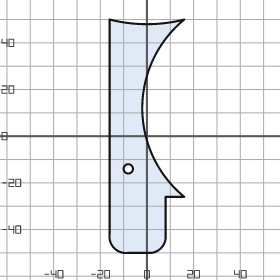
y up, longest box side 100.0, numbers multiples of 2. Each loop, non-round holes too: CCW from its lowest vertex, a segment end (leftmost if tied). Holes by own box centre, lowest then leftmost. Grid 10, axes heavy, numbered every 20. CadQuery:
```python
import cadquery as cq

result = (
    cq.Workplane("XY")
    .moveTo(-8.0, -50.0)
    .lineTo(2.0, -50.0)
    .threePointArc((6.0, -48.0), (8.0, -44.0))
    .lineTo(8.0, -26.0)
    .lineTo(16.0, -26.0)
    .threePointArc((-2.0, 12.0), (16.0, 50.0))
    .threePointArc((0.0, 48.0), (-16.0, 50.0))
    .lineTo(-16.0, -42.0)
    .threePointArc((-14.0, -48.0), (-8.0, -50.0))
    .close()
    .moveTo(-8.0, -14.0)
    .circle(2.0)
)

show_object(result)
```